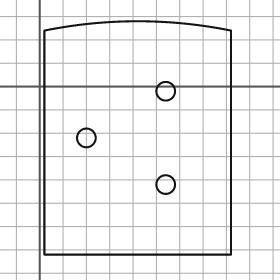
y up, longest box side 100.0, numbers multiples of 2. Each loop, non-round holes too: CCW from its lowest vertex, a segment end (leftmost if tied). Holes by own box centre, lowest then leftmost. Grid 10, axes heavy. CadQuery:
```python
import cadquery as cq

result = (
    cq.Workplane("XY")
    .moveTo(2.0, -72.0)
    .lineTo(82.0, -72.0)
    .lineTo(82.0, 24.0)
    .threePointArc((42.0, 28.0), (2.0, 24.0))
    .close()
    .moveTo(54.0, -42.0)
    .circle(4.0)
    .moveTo(20.0, -22.0)
    .circle(4.0)
    .moveTo(54.0, -2.0)
    .circle(4.0)
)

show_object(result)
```